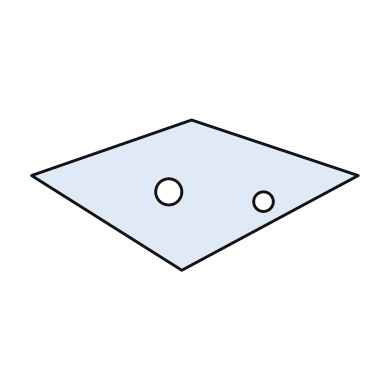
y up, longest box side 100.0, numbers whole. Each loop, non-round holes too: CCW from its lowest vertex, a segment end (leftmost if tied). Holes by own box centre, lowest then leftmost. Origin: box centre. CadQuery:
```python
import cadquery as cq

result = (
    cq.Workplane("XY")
    .moveTo(-4.0, -23.0)
    .lineTo(50.0, 6.0)
    .lineTo(-1.0, 23.0)
    .lineTo(-50.0, 6.0)
    .close()
    .moveTo(21.0, -2.0)
    .circle(3.0)
    .moveTo(-8.0, 1.0)
    .circle(4.0)
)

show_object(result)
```